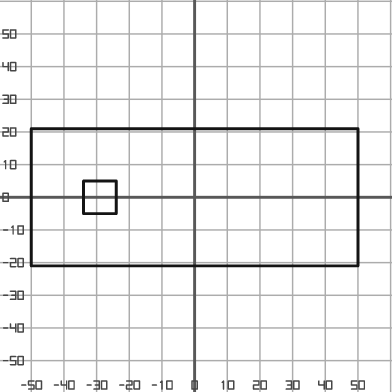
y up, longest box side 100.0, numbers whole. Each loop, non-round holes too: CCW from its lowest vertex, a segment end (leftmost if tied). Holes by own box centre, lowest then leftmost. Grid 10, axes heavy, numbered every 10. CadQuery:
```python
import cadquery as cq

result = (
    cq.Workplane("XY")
    .moveTo(-50.0, -21.0)
    .lineTo(50.0, -21.0)
    .lineTo(50.0, 21.0)
    .lineTo(-50.0, 21.0)
    .close()
    .moveTo(-34.0, -5.0)
    .lineTo(-24.0, -5.0)
    .lineTo(-24.0, 5.0)
    .lineTo(-34.0, 5.0)
    .close()
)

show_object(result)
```